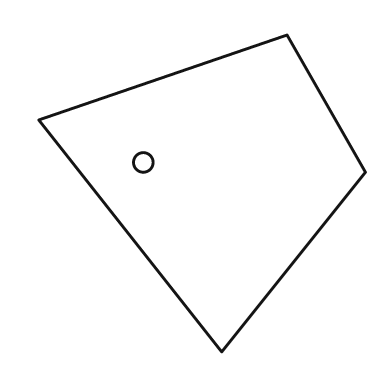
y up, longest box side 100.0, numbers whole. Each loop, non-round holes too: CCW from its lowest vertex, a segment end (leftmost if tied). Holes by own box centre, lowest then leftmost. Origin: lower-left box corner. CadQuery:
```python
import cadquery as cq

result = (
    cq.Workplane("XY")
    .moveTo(56.0, 0.0)
    .lineTo(100.0, 55.0)
    .lineTo(76.0, 97.0)
    .lineTo(0.0, 71.0)
    .close()
    .moveTo(32.0, 58.0)
    .circle(3.0)
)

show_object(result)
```